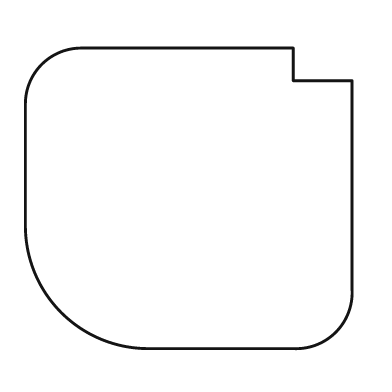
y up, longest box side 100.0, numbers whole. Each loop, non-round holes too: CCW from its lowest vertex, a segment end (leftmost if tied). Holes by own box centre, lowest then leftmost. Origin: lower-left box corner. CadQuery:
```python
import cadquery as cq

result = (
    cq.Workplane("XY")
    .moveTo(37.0, 0.0)
    .lineTo(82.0, 0.0)
    .threePointArc((95.0, 5.0), (100.0, 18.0))
    .lineTo(100.0, 82.0)
    .lineTo(82.0, 82.0)
    .lineTo(82.0, 92.0)
    .lineTo(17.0, 92.0)
    .threePointArc((5.0, 87.0), (0.0, 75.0))
    .lineTo(0.0, 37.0)
    .threePointArc((11.0, 11.0), (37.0, 0.0))
    .close()
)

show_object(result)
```